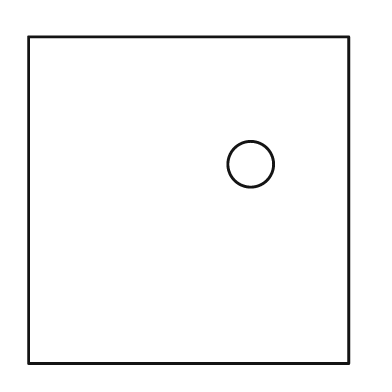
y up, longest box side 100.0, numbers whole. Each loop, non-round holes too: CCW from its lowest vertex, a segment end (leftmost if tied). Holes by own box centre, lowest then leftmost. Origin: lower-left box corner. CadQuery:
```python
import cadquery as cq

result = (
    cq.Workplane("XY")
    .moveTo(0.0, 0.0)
    .lineTo(98.0, 0.0)
    .lineTo(98.0, 100.0)
    .lineTo(0.0, 100.0)
    .close()
    .moveTo(68.0, 61.0)
    .circle(7.0)
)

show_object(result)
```